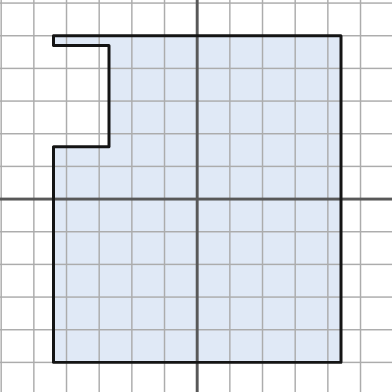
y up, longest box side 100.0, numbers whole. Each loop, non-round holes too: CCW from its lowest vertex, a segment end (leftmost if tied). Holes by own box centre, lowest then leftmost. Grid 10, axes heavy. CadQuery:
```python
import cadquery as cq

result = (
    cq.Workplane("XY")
    .moveTo(-44.0, -50.0)
    .lineTo(44.0, -50.0)
    .lineTo(44.0, 50.0)
    .lineTo(-44.0, 50.0)
    .lineTo(-44.0, 47.0)
    .lineTo(-27.0, 47.0)
    .lineTo(-27.0, 16.0)
    .lineTo(-44.0, 16.0)
    .close()
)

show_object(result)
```